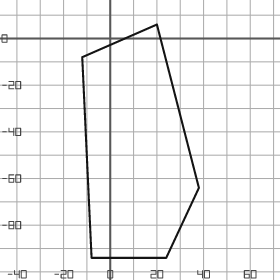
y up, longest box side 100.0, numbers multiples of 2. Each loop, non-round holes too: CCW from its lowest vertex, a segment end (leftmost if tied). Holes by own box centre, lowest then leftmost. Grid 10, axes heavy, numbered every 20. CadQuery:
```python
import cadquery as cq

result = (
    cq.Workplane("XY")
    .moveTo(-8.0, -94.0)
    .lineTo(24.0, -94.0)
    .lineTo(38.0, -64.0)
    .lineTo(20.0, 6.0)
    .lineTo(-12.0, -8.0)
    .close()
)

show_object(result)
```